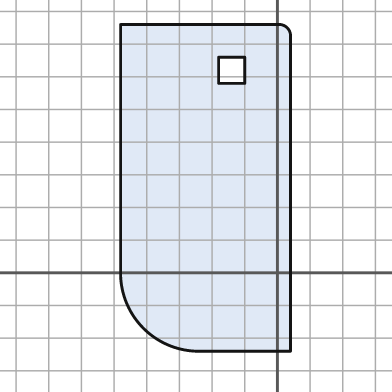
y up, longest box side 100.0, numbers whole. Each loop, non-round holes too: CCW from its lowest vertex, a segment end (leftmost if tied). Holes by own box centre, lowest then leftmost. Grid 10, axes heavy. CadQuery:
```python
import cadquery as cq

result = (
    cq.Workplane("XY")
    .moveTo(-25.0, -24.0)
    .lineTo(4.0, -24.0)
    .lineTo(4.0, 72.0)
    .threePointArc((3.0, 75.0), (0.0, 76.0))
    .lineTo(-48.0, 76.0)
    .lineTo(-48.0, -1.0)
    .threePointArc((-41.0, -17.0), (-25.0, -24.0))
    .close()
    .moveTo(-18.0, 58.0)
    .lineTo(-10.0, 58.0)
    .lineTo(-10.0, 66.0)
    .lineTo(-18.0, 66.0)
    .close()
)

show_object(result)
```